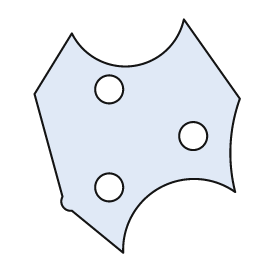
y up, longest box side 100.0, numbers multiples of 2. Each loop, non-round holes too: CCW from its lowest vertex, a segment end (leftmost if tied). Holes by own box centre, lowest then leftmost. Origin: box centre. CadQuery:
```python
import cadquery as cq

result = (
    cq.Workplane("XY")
    .moveTo(-6.0, -50.0)
    .threePointArc((10.0, -22.0), (42.0, -24.0))
    .threePointArc((40.0, -4.0), (44.0, 16.0))
    .lineTo(20.0, 50.0)
    .threePointArc((-2.0, 30.0), (-28.0, 44.0))
    .lineTo(-44.0, 18.0)
    .lineTo(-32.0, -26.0)
    .threePointArc((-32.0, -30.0), (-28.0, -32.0))
    .close()
    .moveTo(-12.0, -22.0)
    .circle(6.0)
    .moveTo(24.0, 0.0)
    .circle(6.0)
    .moveTo(-12.0, 20.0)
    .circle(6.0)
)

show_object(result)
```